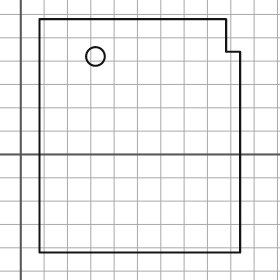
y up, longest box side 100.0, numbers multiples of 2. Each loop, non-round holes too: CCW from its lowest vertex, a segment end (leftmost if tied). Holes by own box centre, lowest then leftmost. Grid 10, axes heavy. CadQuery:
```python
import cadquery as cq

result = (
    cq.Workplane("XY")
    .moveTo(8.0, -42.0)
    .lineTo(94.0, -42.0)
    .lineTo(94.0, 44.0)
    .lineTo(88.0, 44.0)
    .lineTo(88.0, 58.0)
    .lineTo(8.0, 58.0)
    .close()
    .moveTo(32.0, 42.0)
    .circle(4.0)
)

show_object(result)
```